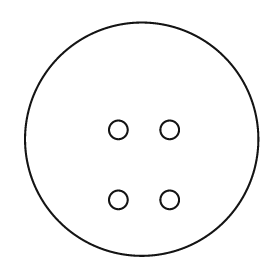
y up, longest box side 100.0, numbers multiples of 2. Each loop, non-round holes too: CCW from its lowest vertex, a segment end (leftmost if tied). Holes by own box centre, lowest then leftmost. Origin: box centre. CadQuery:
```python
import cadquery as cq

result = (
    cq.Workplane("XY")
    .moveTo(0.0, 0.0)
    .circle(50.0)
    .moveTo(-10.0, -26.0)
    .circle(4.0)
    .moveTo(12.0, -26.0)
    .circle(4.0)
    .moveTo(-10.0, 4.0)
    .circle(4.0)
    .moveTo(12.0, 4.0)
    .circle(4.0)
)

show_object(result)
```